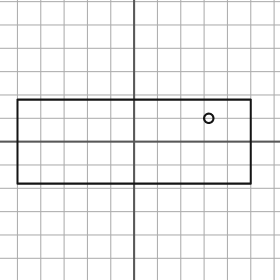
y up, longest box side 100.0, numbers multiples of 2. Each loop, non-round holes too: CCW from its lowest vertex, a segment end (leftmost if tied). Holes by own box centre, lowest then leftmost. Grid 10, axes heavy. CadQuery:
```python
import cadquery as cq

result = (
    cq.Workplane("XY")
    .moveTo(-50.0, -18.0)
    .lineTo(50.0, -18.0)
    .lineTo(50.0, 18.0)
    .lineTo(-50.0, 18.0)
    .close()
    .moveTo(32.0, 10.0)
    .circle(2.0)
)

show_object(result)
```